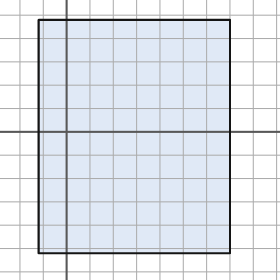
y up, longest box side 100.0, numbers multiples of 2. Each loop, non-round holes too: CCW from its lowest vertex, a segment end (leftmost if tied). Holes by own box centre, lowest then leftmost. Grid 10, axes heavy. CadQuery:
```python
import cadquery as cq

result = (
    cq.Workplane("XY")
    .moveTo(-12.0, -52.0)
    .lineTo(70.0, -52.0)
    .lineTo(70.0, 48.0)
    .lineTo(-12.0, 48.0)
    .close()
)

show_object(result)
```